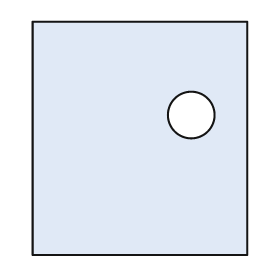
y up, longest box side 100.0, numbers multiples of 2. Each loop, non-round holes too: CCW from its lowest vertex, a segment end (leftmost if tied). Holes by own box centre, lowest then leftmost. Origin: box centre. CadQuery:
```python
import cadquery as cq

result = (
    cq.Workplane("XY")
    .moveTo(-46.0, -50.0)
    .lineTo(46.0, -50.0)
    .lineTo(46.0, 50.0)
    .lineTo(-46.0, 50.0)
    .close()
    .moveTo(22.0, 10.0)
    .circle(10.0)
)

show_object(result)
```